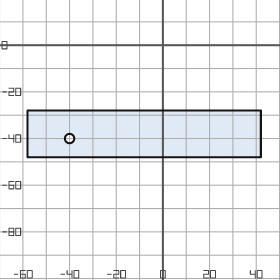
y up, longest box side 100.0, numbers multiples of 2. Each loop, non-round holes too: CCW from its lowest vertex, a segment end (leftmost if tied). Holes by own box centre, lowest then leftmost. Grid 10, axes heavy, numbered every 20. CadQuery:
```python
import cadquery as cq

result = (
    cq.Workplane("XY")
    .moveTo(-58.0, -48.0)
    .lineTo(42.0, -48.0)
    .lineTo(42.0, -28.0)
    .lineTo(-58.0, -28.0)
    .close()
    .moveTo(-40.0, -40.0)
    .circle(2.0)
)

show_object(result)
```